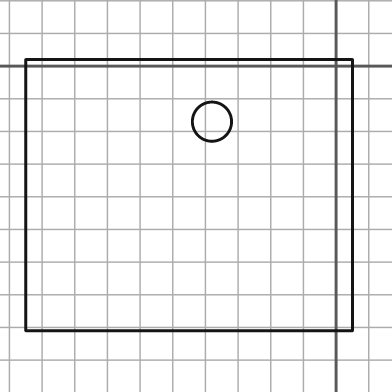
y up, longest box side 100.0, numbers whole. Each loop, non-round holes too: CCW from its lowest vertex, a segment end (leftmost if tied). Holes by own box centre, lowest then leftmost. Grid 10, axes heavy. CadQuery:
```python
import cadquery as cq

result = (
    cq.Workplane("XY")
    .moveTo(-95.0, -81.0)
    .lineTo(5.0, -81.0)
    .lineTo(5.0, 2.0)
    .lineTo(-95.0, 2.0)
    .close()
    .moveTo(-38.0, -17.0)
    .circle(6.0)
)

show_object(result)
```